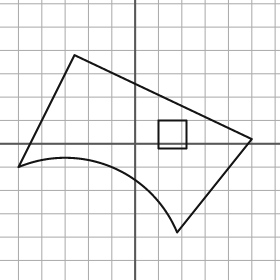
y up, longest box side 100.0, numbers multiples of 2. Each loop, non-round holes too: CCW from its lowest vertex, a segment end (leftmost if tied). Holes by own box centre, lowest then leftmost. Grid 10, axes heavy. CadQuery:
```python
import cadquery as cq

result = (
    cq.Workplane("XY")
    .moveTo(18.0, -38.0)
    .lineTo(50.0, 2.0)
    .lineTo(-26.0, 38.0)
    .lineTo(-50.0, -10.0)
    .threePointArc((-10.0, -10.0), (18.0, -38.0))
    .close()
    .moveTo(10.0, -2.0)
    .lineTo(22.0, -2.0)
    .lineTo(22.0, 10.0)
    .lineTo(10.0, 10.0)
    .close()
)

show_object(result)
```